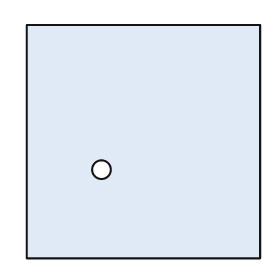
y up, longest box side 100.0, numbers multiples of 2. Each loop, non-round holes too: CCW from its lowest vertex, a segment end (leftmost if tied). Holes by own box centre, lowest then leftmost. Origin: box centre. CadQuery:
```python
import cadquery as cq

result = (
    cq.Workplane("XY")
    .moveTo(-50.0, -50.0)
    .lineTo(50.0, -50.0)
    .lineTo(50.0, 50.0)
    .lineTo(-50.0, 50.0)
    .close()
    .moveTo(-18.0, -12.0)
    .circle(4.0)
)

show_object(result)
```